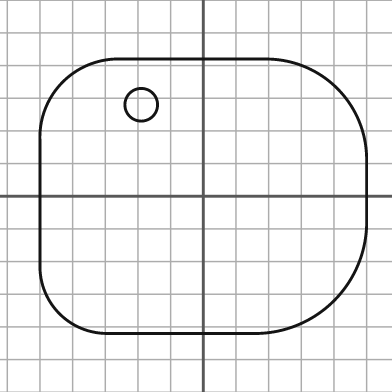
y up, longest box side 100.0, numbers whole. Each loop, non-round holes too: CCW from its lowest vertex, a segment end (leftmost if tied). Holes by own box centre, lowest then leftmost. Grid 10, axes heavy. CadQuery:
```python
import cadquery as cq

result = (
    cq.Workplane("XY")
    .moveTo(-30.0, -42.0)
    .lineTo(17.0, -42.0)
    .threePointArc((40.0, -32.0), (50.0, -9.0))
    .lineTo(50.0, 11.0)
    .threePointArc((41.0, 33.0), (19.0, 42.0))
    .lineTo(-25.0, 42.0)
    .threePointArc((-43.0, 35.0), (-50.0, 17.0))
    .lineTo(-50.0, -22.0)
    .threePointArc((-44.0, -36.0), (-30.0, -42.0))
    .close()
    .moveTo(-19.0, 28.0)
    .circle(5.0)
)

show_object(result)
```